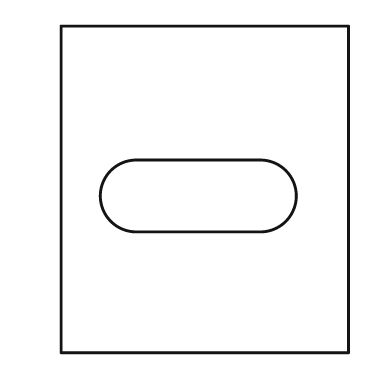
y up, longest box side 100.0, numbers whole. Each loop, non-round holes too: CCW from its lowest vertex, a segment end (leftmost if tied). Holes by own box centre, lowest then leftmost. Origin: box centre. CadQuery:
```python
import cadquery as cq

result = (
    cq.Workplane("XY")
    .moveTo(-44.0, -50.0)
    .lineTo(44.0, -50.0)
    .lineTo(44.0, 50.0)
    .lineTo(-44.0, 50.0)
    .close()
    .moveTo(-21.0, -13.0)
    .lineTo(17.0, -13.0)
    .threePointArc((28.0, -2.0), (17.0, 9.0))
    .lineTo(-21.0, 9.0)
    .threePointArc((-32.0, -2.0), (-21.0, -13.0))
    .close()
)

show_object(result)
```